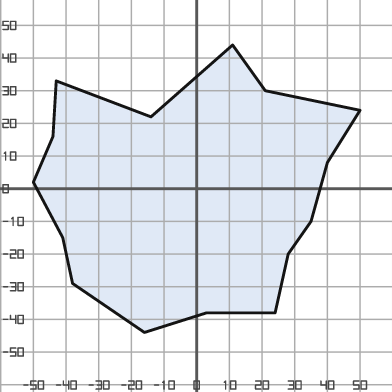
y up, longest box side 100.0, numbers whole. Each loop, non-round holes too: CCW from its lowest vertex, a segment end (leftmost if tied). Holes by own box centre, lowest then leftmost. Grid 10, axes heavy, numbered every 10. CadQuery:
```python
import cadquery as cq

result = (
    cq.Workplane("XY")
    .moveTo(-16.0, -44.0)
    .lineTo(3.0, -38.0)
    .lineTo(24.0, -38.0)
    .lineTo(28.0, -20.0)
    .lineTo(35.0, -10.0)
    .lineTo(40.0, 8.0)
    .lineTo(50.0, 24.0)
    .lineTo(21.0, 30.0)
    .lineTo(11.0, 44.0)
    .lineTo(-14.0, 22.0)
    .lineTo(-43.0, 33.0)
    .lineTo(-44.0, 16.0)
    .lineTo(-50.0, 2.0)
    .lineTo(-41.0, -15.0)
    .lineTo(-38.0, -29.0)
    .close()
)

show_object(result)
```